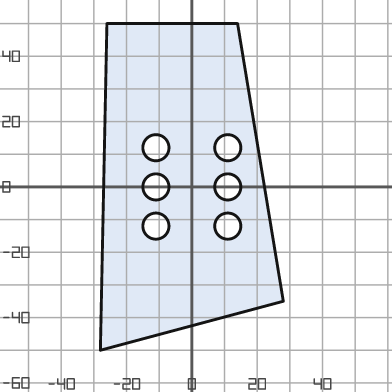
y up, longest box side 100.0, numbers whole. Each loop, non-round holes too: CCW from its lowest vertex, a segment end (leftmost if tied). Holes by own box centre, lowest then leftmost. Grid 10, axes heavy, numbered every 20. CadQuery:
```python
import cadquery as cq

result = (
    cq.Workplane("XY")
    .moveTo(-28.0, -50.0)
    .lineTo(28.0, -35.0)
    .lineTo(14.0, 50.0)
    .lineTo(-26.0, 50.0)
    .close()
    .moveTo(-11.0, -12.0)
    .circle(4.0)
    .moveTo(11.0, -12.0)
    .circle(4.0)
    .moveTo(-11.0, 0.0)
    .circle(4.0)
    .moveTo(11.0, 0.0)
    .circle(4.0)
    .moveTo(-11.0, 12.0)
    .circle(4.0)
    .moveTo(11.0, 12.0)
    .circle(4.0)
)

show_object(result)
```